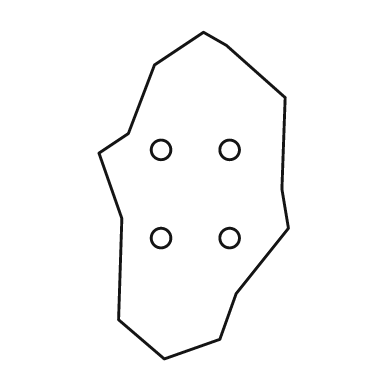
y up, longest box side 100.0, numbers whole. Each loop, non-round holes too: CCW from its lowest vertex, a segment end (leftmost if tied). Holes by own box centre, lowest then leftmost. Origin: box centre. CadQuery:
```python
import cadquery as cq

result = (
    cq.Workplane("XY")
    .moveTo(-9.0, -50.0)
    .lineTo(8.0, -44.0)
    .lineTo(13.0, -30.0)
    .lineTo(29.0, -10.0)
    .lineTo(27.0, 2.0)
    .lineTo(28.0, 30.0)
    .lineTo(10.0, 46.0)
    .lineTo(3.0, 50.0)
    .lineTo(-12.0, 40.0)
    .lineTo(-20.0, 19.0)
    .lineTo(-29.0, 13.0)
    .lineTo(-22.0, -7.0)
    .lineTo(-23.0, -38.0)
    .close()
    .moveTo(-10.0, -13.0)
    .circle(3.0)
    .moveTo(11.0, -13.0)
    .circle(3.0)
    .moveTo(-10.0, 14.0)
    .circle(3.0)
    .moveTo(11.0, 14.0)
    .circle(3.0)
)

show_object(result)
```